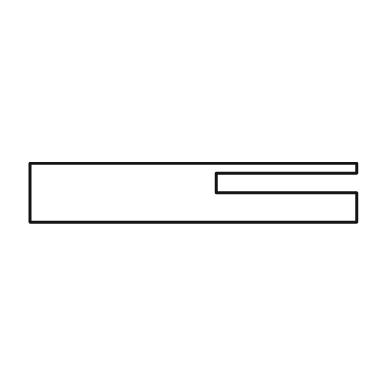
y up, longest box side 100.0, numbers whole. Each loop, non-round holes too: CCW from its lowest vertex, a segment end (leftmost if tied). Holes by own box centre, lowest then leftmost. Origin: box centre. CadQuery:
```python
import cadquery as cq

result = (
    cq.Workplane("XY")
    .moveTo(-50.0, -9.0)
    .lineTo(50.0, -9.0)
    .lineTo(50.0, 0.0)
    .lineTo(7.0, 0.0)
    .lineTo(7.0, 6.0)
    .lineTo(50.0, 6.0)
    .lineTo(50.0, 9.0)
    .lineTo(-50.0, 9.0)
    .close()
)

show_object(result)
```